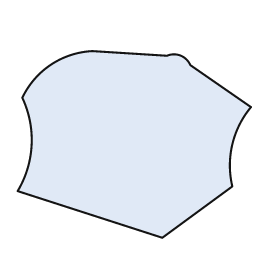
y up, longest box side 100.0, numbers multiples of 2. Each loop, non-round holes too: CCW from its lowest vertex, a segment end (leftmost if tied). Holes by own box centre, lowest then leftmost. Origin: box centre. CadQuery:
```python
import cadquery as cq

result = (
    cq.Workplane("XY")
    .moveTo(12.0, -40.0)
    .lineTo(42.0, -18.0)
    .threePointArc((42.0, 0.0), (50.0, 16.0))
    .lineTo(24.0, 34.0)
    .threePointArc((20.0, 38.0), (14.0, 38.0))
    .lineTo(-18.0, 40.0)
    .threePointArc((-36.0, 34.0), (-48.0, 20.0))
    .threePointArc((-44.0, 0.0), (-50.0, -20.0))
    .close()
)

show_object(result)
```